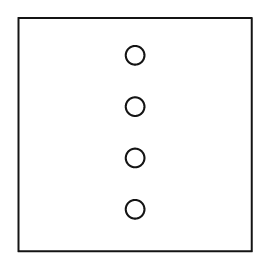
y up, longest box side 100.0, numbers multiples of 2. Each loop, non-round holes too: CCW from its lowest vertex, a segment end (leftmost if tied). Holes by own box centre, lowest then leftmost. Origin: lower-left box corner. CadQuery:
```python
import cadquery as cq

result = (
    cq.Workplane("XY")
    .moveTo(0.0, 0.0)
    .lineTo(100.0, 0.0)
    .lineTo(100.0, 100.0)
    .lineTo(0.0, 100.0)
    .close()
    .moveTo(50.0, 18.0)
    .circle(4.0)
    .moveTo(50.0, 40.0)
    .circle(4.0)
    .moveTo(50.0, 62.0)
    .circle(4.0)
    .moveTo(50.0, 84.0)
    .circle(4.0)
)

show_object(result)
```